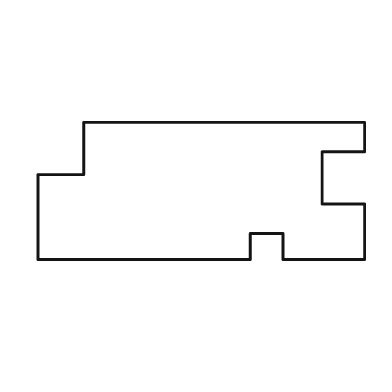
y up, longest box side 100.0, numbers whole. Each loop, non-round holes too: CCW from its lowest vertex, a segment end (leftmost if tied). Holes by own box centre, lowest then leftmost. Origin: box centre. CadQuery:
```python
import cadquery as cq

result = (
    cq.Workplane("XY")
    .moveTo(-50.0, -21.0)
    .lineTo(15.0, -21.0)
    .lineTo(15.0, -13.0)
    .lineTo(25.0, -13.0)
    .lineTo(25.0, -21.0)
    .lineTo(50.0, -21.0)
    .lineTo(50.0, -4.0)
    .lineTo(37.0, -4.0)
    .lineTo(37.0, 12.0)
    .lineTo(50.0, 12.0)
    .lineTo(50.0, 21.0)
    .lineTo(-36.0, 21.0)
    .lineTo(-36.0, 5.0)
    .lineTo(-50.0, 5.0)
    .close()
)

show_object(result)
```